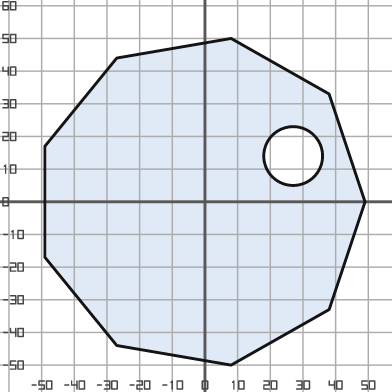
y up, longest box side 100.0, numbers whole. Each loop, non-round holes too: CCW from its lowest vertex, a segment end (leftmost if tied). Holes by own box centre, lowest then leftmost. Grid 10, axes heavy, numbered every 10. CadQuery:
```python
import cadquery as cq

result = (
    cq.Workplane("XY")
    .moveTo(8.0, -50.0)
    .lineTo(38.0, -33.0)
    .lineTo(49.0, 0.0)
    .lineTo(38.0, 33.0)
    .lineTo(8.0, 50.0)
    .lineTo(-27.0, 44.0)
    .lineTo(-49.0, 17.0)
    .lineTo(-49.0, -17.0)
    .lineTo(-27.0, -44.0)
    .close()
    .moveTo(27.0, 14.0)
    .circle(9.0)
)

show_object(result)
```